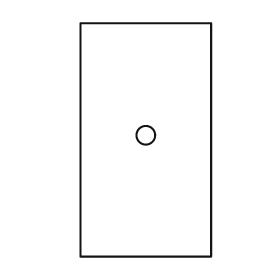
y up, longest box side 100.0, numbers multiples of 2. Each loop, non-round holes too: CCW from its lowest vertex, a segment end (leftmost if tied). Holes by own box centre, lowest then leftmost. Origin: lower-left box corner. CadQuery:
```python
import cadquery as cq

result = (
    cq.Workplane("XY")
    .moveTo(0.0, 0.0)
    .lineTo(56.0, 0.0)
    .lineTo(56.0, 100.0)
    .lineTo(0.0, 100.0)
    .close()
    .moveTo(28.0, 52.0)
    .circle(4.0)
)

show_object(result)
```